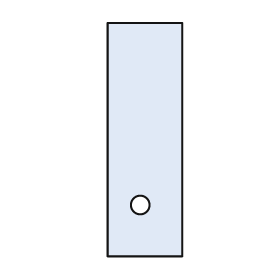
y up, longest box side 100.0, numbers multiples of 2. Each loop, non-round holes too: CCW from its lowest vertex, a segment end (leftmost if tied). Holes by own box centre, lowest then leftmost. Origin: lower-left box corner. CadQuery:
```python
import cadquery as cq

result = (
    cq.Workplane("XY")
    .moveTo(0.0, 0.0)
    .lineTo(32.0, 0.0)
    .lineTo(32.0, 100.0)
    .lineTo(0.0, 100.0)
    .close()
    .moveTo(14.0, 22.0)
    .circle(4.0)
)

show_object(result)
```